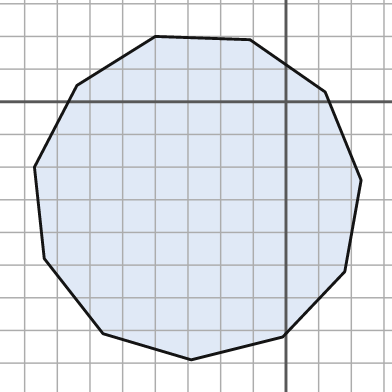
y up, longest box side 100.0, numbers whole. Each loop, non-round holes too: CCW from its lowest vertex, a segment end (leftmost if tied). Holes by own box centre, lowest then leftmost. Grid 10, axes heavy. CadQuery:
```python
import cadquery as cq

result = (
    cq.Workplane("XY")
    .moveTo(-29.0, -79.0)
    .lineTo(-1.0, -72.0)
    .lineTo(18.0, -52.0)
    .lineTo(23.0, -24.0)
    .lineTo(12.0, 3.0)
    .lineTo(-11.0, 19.0)
    .lineTo(-40.0, 20.0)
    .lineTo(-64.0, 5.0)
    .lineTo(-77.0, -20.0)
    .lineTo(-74.0, -48.0)
    .lineTo(-56.0, -71.0)
    .close()
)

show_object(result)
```